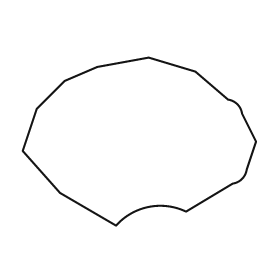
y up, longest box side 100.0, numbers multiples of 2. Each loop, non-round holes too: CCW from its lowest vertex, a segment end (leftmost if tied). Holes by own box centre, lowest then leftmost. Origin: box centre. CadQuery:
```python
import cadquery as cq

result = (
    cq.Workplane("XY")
    .moveTo(-10.0, -36.0)
    .threePointArc((4.0, -28.0), (20.0, -30.0))
    .lineTo(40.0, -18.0)
    .threePointArc((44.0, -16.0), (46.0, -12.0))
    .lineTo(50.0, 0.0)
    .lineTo(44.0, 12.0)
    .threePointArc((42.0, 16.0), (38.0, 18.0))
    .lineTo(24.0, 30.0)
    .lineTo(4.0, 36.0)
    .lineTo(-18.0, 32.0)
    .lineTo(-32.0, 26.0)
    .lineTo(-44.0, 14.0)
    .lineTo(-50.0, -4.0)
    .lineTo(-34.0, -22.0)
    .close()
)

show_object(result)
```